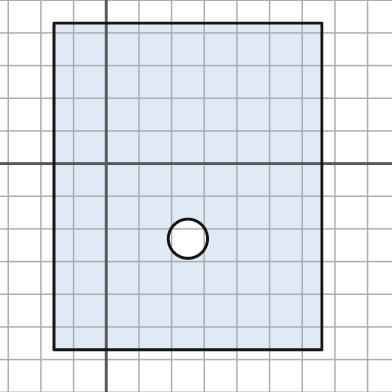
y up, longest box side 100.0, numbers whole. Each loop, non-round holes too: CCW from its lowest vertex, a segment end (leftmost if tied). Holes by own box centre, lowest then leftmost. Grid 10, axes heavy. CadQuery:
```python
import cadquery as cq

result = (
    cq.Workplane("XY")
    .moveTo(-16.0, -57.0)
    .lineTo(66.0, -57.0)
    .lineTo(66.0, 43.0)
    .lineTo(-16.0, 43.0)
    .close()
    .moveTo(25.0, -23.0)
    .circle(6.0)
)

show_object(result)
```